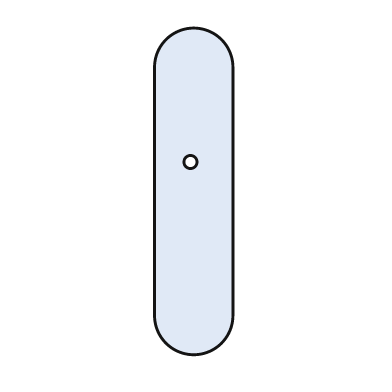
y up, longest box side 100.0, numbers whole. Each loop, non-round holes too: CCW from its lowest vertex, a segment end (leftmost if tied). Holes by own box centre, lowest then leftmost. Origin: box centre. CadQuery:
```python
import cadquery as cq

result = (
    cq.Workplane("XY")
    .moveTo(-12.0, -38.0)
    .threePointArc((0.0, -50.0), (12.0, -38.0))
    .lineTo(12.0, 38.0)
    .threePointArc((0.0, 50.0), (-12.0, 38.0))
    .close()
    .moveTo(-1.0, 9.0)
    .circle(2.0)
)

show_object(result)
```